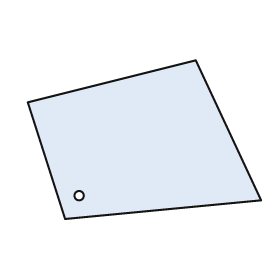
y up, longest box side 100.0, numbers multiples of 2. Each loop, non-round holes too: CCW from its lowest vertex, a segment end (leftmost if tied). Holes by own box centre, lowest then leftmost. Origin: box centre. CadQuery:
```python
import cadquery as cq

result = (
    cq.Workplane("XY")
    .moveTo(-34.0, -34.0)
    .lineTo(50.0, -26.0)
    .lineTo(22.0, 34.0)
    .lineTo(-50.0, 16.0)
    .close()
    .moveTo(-28.0, -24.0)
    .circle(2.0)
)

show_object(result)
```